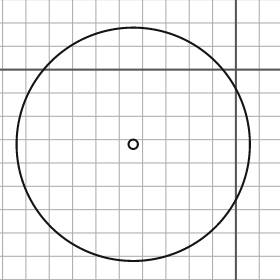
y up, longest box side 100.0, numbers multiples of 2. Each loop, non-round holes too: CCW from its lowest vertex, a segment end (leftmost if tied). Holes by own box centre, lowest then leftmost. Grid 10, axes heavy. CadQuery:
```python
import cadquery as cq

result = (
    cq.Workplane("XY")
    .moveTo(-44.0, -32.0)
    .circle(50.0)
    .moveTo(-44.0, -32.0)
    .circle(2.0)
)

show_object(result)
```